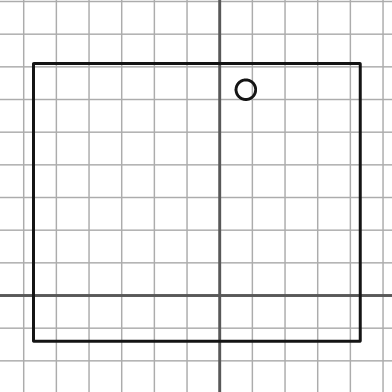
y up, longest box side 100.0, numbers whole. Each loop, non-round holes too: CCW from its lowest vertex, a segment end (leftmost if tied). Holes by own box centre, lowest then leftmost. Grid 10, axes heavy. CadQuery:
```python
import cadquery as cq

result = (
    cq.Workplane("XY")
    .moveTo(-57.0, -14.0)
    .lineTo(43.0, -14.0)
    .lineTo(43.0, 71.0)
    .lineTo(-57.0, 71.0)
    .close()
    .moveTo(8.0, 63.0)
    .circle(3.0)
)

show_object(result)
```